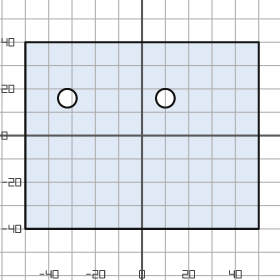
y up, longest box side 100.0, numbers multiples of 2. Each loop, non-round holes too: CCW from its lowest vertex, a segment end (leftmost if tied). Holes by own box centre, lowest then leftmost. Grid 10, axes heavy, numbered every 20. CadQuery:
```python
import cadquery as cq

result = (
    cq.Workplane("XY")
    .moveTo(-50.0, -40.0)
    .lineTo(50.0, -40.0)
    .lineTo(50.0, 40.0)
    .lineTo(-50.0, 40.0)
    .close()
    .moveTo(-32.0, 16.0)
    .circle(4.0)
    .moveTo(10.0, 16.0)
    .circle(4.0)
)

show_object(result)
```